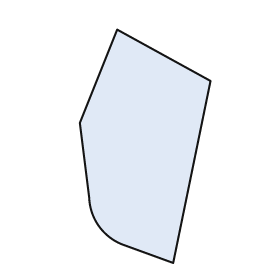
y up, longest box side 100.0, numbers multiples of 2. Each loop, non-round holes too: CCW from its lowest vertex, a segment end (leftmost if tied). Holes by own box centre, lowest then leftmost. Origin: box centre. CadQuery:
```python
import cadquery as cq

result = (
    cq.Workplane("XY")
    .moveTo(12.0, -50.0)
    .lineTo(28.0, 28.0)
    .lineTo(-12.0, 50.0)
    .lineTo(-28.0, 10.0)
    .lineTo(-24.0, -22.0)
    .threePointArc((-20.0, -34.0), (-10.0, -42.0))
    .close()
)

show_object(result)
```